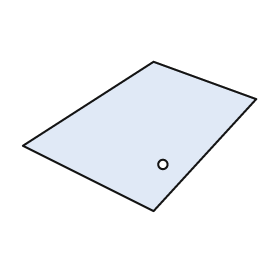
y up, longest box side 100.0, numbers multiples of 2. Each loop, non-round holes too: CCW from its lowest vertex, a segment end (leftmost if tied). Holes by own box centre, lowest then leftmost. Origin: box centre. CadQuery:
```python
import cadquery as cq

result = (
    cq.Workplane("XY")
    .moveTo(6.0, -32.0)
    .lineTo(50.0, 16.0)
    .lineTo(6.0, 32.0)
    .lineTo(-50.0, -4.0)
    .close()
    .moveTo(10.0, -12.0)
    .circle(2.0)
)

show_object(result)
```